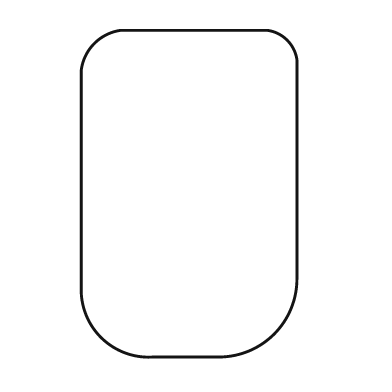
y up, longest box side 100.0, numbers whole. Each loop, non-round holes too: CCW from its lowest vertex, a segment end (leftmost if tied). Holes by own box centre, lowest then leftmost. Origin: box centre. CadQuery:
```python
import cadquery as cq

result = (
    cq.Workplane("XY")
    .moveTo(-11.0, -50.0)
    .lineTo(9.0, -50.0)
    .threePointArc((26.0, -43.0), (33.0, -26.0))
    .lineTo(33.0, 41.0)
    .threePointArc((30.0, 47.0), (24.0, 50.0))
    .lineTo(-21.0, 50.0)
    .threePointArc((-29.0, 46.0), (-33.0, 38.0))
    .lineTo(-33.0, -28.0)
    .threePointArc((-27.0, -44.0), (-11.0, -50.0))
    .close()
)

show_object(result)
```